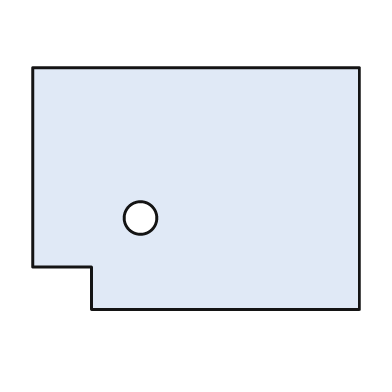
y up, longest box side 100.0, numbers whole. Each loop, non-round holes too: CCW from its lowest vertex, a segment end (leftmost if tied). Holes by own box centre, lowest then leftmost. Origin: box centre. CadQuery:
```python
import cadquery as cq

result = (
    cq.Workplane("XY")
    .moveTo(-32.0, -37.0)
    .lineTo(50.0, -37.0)
    .lineTo(50.0, 37.0)
    .lineTo(-50.0, 37.0)
    .lineTo(-50.0, -24.0)
    .lineTo(-32.0, -24.0)
    .close()
    .moveTo(-17.0, -9.0)
    .circle(5.0)
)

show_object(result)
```